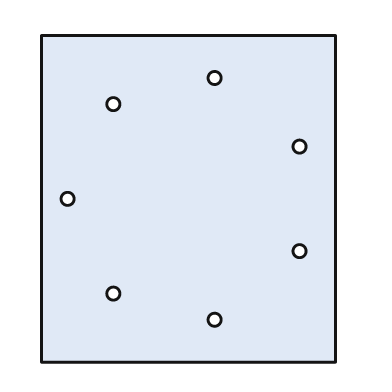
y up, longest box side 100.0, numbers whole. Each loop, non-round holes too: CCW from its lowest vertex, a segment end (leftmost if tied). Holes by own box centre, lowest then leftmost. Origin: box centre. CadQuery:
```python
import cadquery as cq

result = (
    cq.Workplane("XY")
    .moveTo(-45.0, -50.0)
    .lineTo(45.0, -50.0)
    .lineTo(45.0, 50.0)
    .lineTo(-45.0, 50.0)
    .close()
    .moveTo(8.0, -37.0)
    .circle(2.0)
    .moveTo(-23.0, -29.0)
    .circle(2.0)
    .moveTo(34.0, -16.0)
    .circle(2.0)
    .moveTo(-37.0, 0.0)
    .circle(2.0)
    .moveTo(34.0, 16.0)
    .circle(2.0)
    .moveTo(-23.0, 29.0)
    .circle(2.0)
    .moveTo(8.0, 37.0)
    .circle(2.0)
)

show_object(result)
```